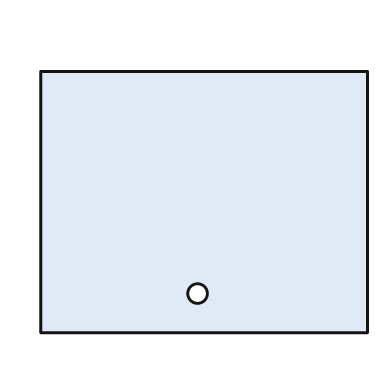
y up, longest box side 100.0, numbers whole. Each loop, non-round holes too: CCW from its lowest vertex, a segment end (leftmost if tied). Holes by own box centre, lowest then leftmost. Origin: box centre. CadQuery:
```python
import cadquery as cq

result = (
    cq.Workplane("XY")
    .moveTo(-50.0, -40.0)
    .lineTo(50.0, -40.0)
    .lineTo(50.0, 40.0)
    .lineTo(-50.0, 40.0)
    .close()
    .moveTo(-2.0, -28.0)
    .circle(3.0)
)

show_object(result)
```